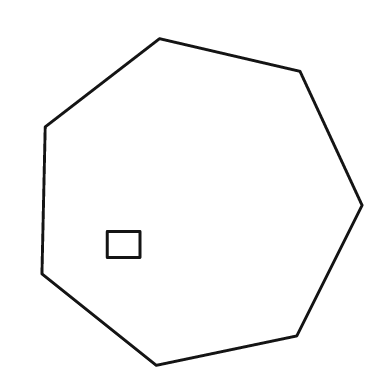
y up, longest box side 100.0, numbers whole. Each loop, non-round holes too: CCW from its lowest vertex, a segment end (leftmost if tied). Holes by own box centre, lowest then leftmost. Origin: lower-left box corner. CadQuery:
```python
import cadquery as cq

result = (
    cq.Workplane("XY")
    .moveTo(35.0, 0.0)
    .lineTo(78.0, 9.0)
    .lineTo(98.0, 49.0)
    .lineTo(79.0, 90.0)
    .lineTo(36.0, 100.0)
    .lineTo(1.0, 73.0)
    .lineTo(0.0, 28.0)
    .close()
    .moveTo(20.0, 33.0)
    .lineTo(30.0, 33.0)
    .lineTo(30.0, 41.0)
    .lineTo(20.0, 41.0)
    .close()
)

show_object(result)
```